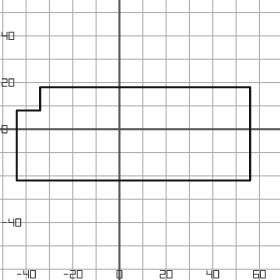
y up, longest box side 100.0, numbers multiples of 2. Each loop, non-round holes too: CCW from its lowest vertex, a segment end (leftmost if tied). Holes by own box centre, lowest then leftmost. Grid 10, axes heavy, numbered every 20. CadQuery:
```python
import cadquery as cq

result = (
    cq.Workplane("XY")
    .moveTo(-44.0, -22.0)
    .lineTo(56.0, -22.0)
    .lineTo(56.0, 18.0)
    .lineTo(-34.0, 18.0)
    .lineTo(-34.0, 8.0)
    .lineTo(-44.0, 8.0)
    .close()
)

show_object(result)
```